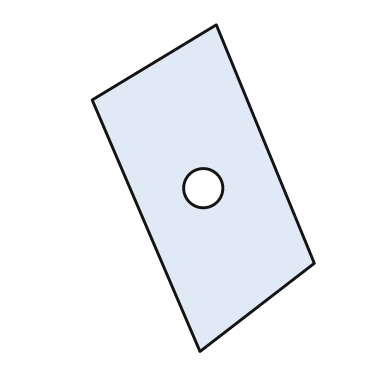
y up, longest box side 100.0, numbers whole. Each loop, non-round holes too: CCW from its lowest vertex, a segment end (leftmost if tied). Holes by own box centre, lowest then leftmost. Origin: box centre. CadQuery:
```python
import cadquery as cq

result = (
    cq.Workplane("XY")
    .moveTo(-1.0, -50.0)
    .lineTo(34.0, -23.0)
    .lineTo(4.0, 50.0)
    .lineTo(-34.0, 27.0)
    .close()
    .moveTo(0.0, 0.0)
    .circle(6.0)
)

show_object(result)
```